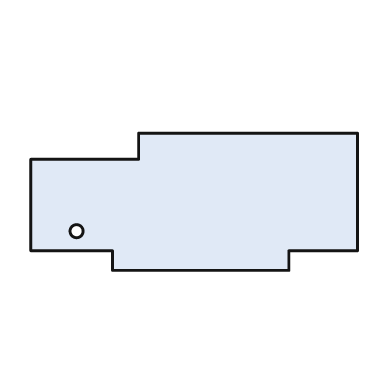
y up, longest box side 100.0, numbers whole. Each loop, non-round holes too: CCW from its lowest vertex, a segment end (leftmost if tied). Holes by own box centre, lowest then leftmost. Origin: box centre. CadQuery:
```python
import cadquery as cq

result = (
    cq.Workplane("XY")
    .moveTo(-25.0, -21.0)
    .lineTo(29.0, -21.0)
    .lineTo(29.0, -15.0)
    .lineTo(50.0, -15.0)
    .lineTo(50.0, 21.0)
    .lineTo(-17.0, 21.0)
    .lineTo(-17.0, 13.0)
    .lineTo(-50.0, 13.0)
    .lineTo(-50.0, -15.0)
    .lineTo(-25.0, -15.0)
    .close()
    .moveTo(-36.0, -9.0)
    .circle(2.0)
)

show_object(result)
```